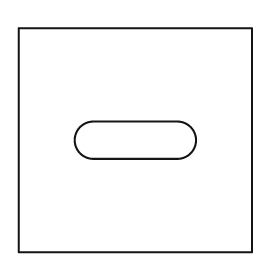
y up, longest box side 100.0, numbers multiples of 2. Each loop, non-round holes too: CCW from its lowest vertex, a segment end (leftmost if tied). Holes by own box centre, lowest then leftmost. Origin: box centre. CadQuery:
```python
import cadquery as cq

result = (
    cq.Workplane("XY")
    .moveTo(-50.0, -48.0)
    .lineTo(50.0, -48.0)
    .lineTo(50.0, 48.0)
    .lineTo(-50.0, 48.0)
    .close()
    .moveTo(-18.0, -8.0)
    .lineTo(18.0, -8.0)
    .threePointArc((26.0, 0.0), (18.0, 8.0))
    .lineTo(-18.0, 8.0)
    .threePointArc((-26.0, 0.0), (-18.0, -8.0))
    .close()
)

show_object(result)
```